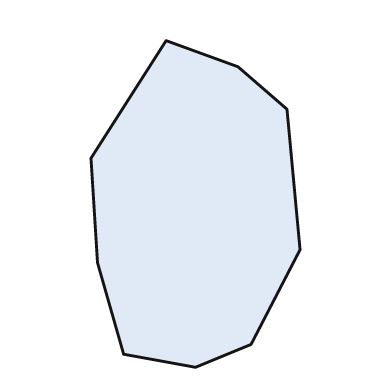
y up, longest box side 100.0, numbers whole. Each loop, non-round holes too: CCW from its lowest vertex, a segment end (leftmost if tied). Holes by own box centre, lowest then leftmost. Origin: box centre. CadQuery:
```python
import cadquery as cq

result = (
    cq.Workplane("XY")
    .moveTo(0.0, -50.0)
    .lineTo(17.0, -43.0)
    .lineTo(32.0, -14.0)
    .lineTo(28.0, 29.0)
    .lineTo(13.0, 42.0)
    .lineTo(-9.0, 50.0)
    .lineTo(-32.0, 14.0)
    .lineTo(-30.0, -18.0)
    .lineTo(-22.0, -46.0)
    .close()
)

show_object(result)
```